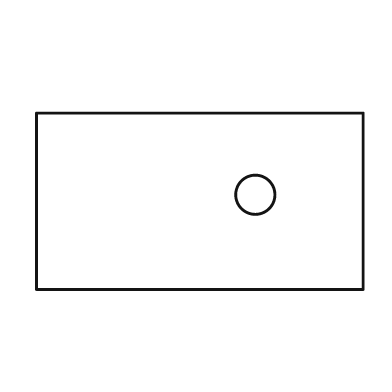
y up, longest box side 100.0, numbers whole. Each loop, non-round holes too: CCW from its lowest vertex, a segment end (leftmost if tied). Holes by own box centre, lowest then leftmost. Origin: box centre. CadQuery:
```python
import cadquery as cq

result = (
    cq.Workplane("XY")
    .moveTo(-50.0, -27.0)
    .lineTo(50.0, -27.0)
    .lineTo(50.0, 27.0)
    .lineTo(-50.0, 27.0)
    .close()
    .moveTo(17.0, 2.0)
    .circle(6.0)
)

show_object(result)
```